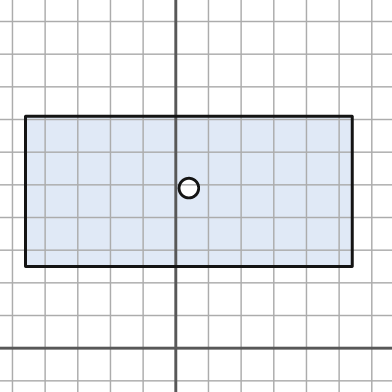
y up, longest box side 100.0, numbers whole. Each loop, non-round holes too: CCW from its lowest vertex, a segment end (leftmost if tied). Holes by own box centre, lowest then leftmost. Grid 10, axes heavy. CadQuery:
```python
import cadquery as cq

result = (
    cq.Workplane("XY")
    .moveTo(-46.0, 25.0)
    .lineTo(54.0, 25.0)
    .lineTo(54.0, 71.0)
    .lineTo(-46.0, 71.0)
    .close()
    .moveTo(4.0, 49.0)
    .circle(3.0)
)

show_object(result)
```